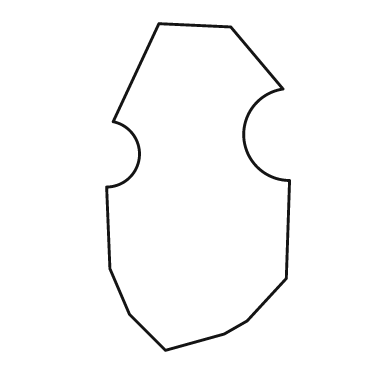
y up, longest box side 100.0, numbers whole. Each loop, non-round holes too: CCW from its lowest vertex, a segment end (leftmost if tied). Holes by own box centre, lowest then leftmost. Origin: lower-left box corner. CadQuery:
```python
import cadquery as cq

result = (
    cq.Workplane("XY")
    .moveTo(18.0, 0.0)
    .lineTo(36.0, 5.0)
    .lineTo(43.0, 9.0)
    .lineTo(55.0, 22.0)
    .lineTo(56.0, 52.0)
    .threePointArc((42.0, 65.0), (54.0, 80.0))
    .lineTo(38.0, 99.0)
    .lineTo(16.0, 100.0)
    .lineTo(2.0, 70.0)
    .threePointArc((10.0, 59.0), (0.0, 50.0))
    .lineTo(1.0, 25.0)
    .lineTo(7.0, 11.0)
    .close()
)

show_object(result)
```